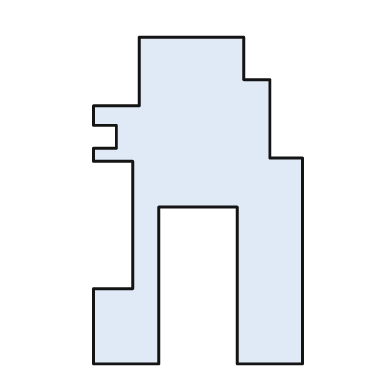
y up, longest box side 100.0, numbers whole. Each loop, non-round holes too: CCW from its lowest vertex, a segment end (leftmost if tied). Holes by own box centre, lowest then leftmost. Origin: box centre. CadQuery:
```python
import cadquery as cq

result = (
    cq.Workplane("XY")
    .moveTo(-32.0, -50.0)
    .lineTo(-12.0, -50.0)
    .lineTo(-12.0, -2.0)
    .lineTo(12.0, -2.0)
    .lineTo(12.0, -50.0)
    .lineTo(32.0, -50.0)
    .lineTo(32.0, 13.0)
    .lineTo(22.0, 13.0)
    .lineTo(22.0, 37.0)
    .lineTo(14.0, 37.0)
    .lineTo(14.0, 50.0)
    .lineTo(-18.0, 50.0)
    .lineTo(-18.0, 29.0)
    .lineTo(-32.0, 29.0)
    .lineTo(-32.0, 23.0)
    .lineTo(-25.0, 23.0)
    .lineTo(-25.0, 16.0)
    .lineTo(-32.0, 16.0)
    .lineTo(-32.0, 12.0)
    .lineTo(-20.0, 12.0)
    .lineTo(-20.0, -27.0)
    .lineTo(-32.0, -27.0)
    .close()
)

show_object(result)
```